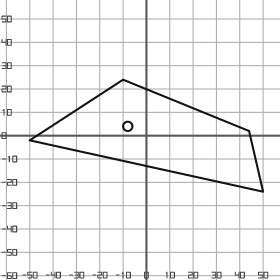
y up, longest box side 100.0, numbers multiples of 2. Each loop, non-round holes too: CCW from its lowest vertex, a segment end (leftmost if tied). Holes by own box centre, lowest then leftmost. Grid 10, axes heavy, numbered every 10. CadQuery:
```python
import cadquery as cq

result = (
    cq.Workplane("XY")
    .moveTo(50.0, -24.0)
    .lineTo(44.0, 2.0)
    .lineTo(-10.0, 24.0)
    .lineTo(-50.0, -2.0)
    .close()
    .moveTo(-8.0, 4.0)
    .circle(2.0)
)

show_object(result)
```